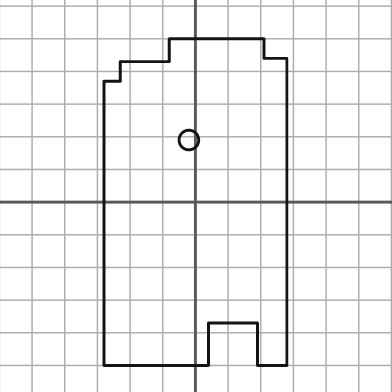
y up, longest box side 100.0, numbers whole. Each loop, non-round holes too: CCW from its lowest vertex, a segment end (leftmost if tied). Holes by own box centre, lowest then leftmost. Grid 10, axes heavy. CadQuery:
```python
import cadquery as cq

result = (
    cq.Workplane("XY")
    .moveTo(-28.0, -50.0)
    .lineTo(4.0, -50.0)
    .lineTo(4.0, -37.0)
    .lineTo(19.0, -37.0)
    .lineTo(19.0, -50.0)
    .lineTo(28.0, -50.0)
    .lineTo(28.0, 44.0)
    .lineTo(21.0, 44.0)
    .lineTo(21.0, 50.0)
    .lineTo(-8.0, 50.0)
    .lineTo(-8.0, 43.0)
    .lineTo(-23.0, 43.0)
    .lineTo(-23.0, 37.0)
    .lineTo(-28.0, 37.0)
    .close()
    .moveTo(-2.0, 19.0)
    .circle(3.0)
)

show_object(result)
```